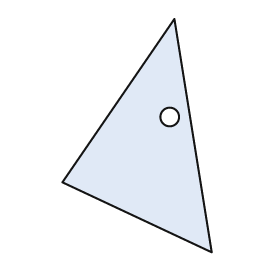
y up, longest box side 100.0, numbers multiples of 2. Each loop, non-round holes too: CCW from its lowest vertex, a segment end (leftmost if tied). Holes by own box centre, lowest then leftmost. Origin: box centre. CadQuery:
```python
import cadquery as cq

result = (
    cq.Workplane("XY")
    .moveTo(32.0, -50.0)
    .lineTo(16.0, 50.0)
    .lineTo(-32.0, -20.0)
    .close()
    .moveTo(14.0, 8.0)
    .circle(4.0)
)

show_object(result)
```